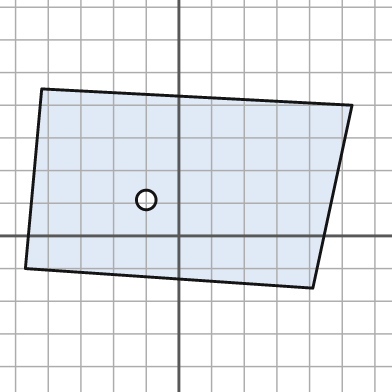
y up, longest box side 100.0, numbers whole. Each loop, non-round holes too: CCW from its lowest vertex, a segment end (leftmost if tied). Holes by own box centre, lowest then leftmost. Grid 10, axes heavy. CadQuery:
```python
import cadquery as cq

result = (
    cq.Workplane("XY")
    .moveTo(41.0, -16.0)
    .lineTo(53.0, 40.0)
    .lineTo(-42.0, 45.0)
    .lineTo(-47.0, -10.0)
    .close()
    .moveTo(-10.0, 11.0)
    .circle(3.0)
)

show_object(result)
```